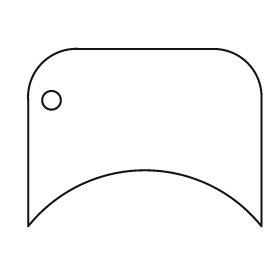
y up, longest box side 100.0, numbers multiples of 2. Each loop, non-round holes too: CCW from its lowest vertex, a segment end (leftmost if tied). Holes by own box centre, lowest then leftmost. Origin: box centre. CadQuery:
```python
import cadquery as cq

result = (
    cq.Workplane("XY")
    .moveTo(-50.0, -38.0)
    .threePointArc((0.0, -14.0), (50.0, -38.0))
    .lineTo(50.0, 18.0)
    .threePointArc((44.0, 32.0), (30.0, 38.0))
    .lineTo(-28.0, 38.0)
    .threePointArc((-44.0, 32.0), (-50.0, 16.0))
    .close()
    .moveTo(-40.0, 16.0)
    .circle(4.0)
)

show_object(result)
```